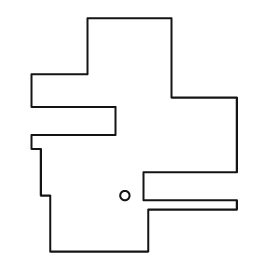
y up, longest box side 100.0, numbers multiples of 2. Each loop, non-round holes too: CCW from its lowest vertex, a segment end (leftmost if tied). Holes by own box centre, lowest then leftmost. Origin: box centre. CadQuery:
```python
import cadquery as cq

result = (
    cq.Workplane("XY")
    .moveTo(-36.0, -50.0)
    .lineTo(6.0, -50.0)
    .lineTo(6.0, -32.0)
    .lineTo(44.0, -32.0)
    .lineTo(44.0, -28.0)
    .lineTo(4.0, -28.0)
    .lineTo(4.0, -16.0)
    .lineTo(44.0, -16.0)
    .lineTo(44.0, 16.0)
    .lineTo(16.0, 16.0)
    .lineTo(16.0, 50.0)
    .lineTo(-20.0, 50.0)
    .lineTo(-20.0, 26.0)
    .lineTo(-44.0, 26.0)
    .lineTo(-44.0, 12.0)
    .lineTo(-8.0, 12.0)
    .lineTo(-8.0, 0.0)
    .lineTo(-44.0, 0.0)
    .lineTo(-44.0, -6.0)
    .lineTo(-40.0, -6.0)
    .lineTo(-40.0, -26.0)
    .lineTo(-36.0, -26.0)
    .close()
    .moveTo(-4.0, -26.0)
    .circle(2.0)
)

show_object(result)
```